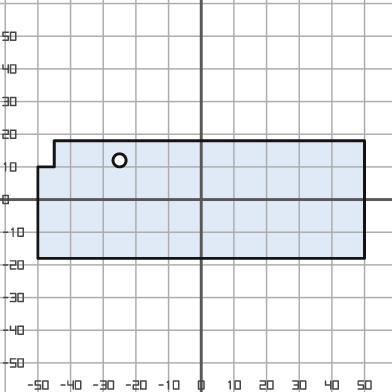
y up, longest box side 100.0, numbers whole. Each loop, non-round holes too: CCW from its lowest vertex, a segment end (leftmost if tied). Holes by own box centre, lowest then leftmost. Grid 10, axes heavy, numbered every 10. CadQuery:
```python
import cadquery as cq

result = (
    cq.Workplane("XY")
    .moveTo(-50.0, -18.0)
    .lineTo(50.0, -18.0)
    .lineTo(50.0, 18.0)
    .lineTo(-45.0, 18.0)
    .lineTo(-45.0, 10.0)
    .lineTo(-50.0, 10.0)
    .close()
    .moveTo(-25.0, 12.0)
    .circle(2.0)
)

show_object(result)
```